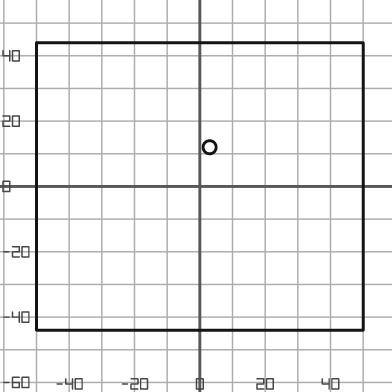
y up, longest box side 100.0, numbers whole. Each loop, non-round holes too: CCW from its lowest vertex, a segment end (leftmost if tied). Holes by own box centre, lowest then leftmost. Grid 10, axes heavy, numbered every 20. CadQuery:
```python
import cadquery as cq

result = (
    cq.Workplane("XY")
    .moveTo(-50.0, -44.0)
    .lineTo(50.0, -44.0)
    .lineTo(50.0, 44.0)
    .lineTo(-50.0, 44.0)
    .close()
    .moveTo(3.0, 12.0)
    .circle(2.0)
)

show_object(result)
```